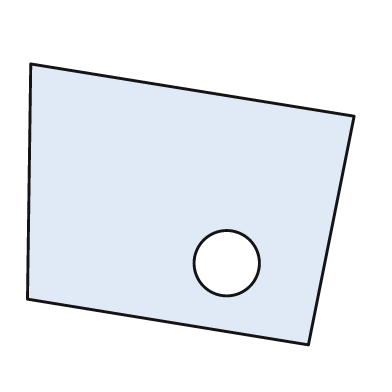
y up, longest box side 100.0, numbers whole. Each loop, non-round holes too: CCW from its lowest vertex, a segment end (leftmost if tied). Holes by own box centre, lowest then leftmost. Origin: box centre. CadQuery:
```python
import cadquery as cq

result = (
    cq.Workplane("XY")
    .moveTo(36.0, -43.0)
    .lineTo(50.0, 27.0)
    .lineTo(-49.0, 43.0)
    .lineTo(-50.0, -29.0)
    .close()
    .moveTo(11.0, -18.0)
    .circle(10.0)
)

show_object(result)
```